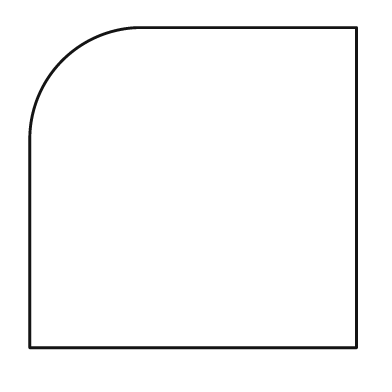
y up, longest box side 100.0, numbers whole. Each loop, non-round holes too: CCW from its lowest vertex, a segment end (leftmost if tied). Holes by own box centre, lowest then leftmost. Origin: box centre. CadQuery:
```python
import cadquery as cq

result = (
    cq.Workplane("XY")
    .moveTo(-50.0, -49.0)
    .lineTo(50.0, -49.0)
    .lineTo(50.0, 49.0)
    .lineTo(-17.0, 49.0)
    .threePointArc((-40.0, 39.0), (-50.0, 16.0))
    .close()
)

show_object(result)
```